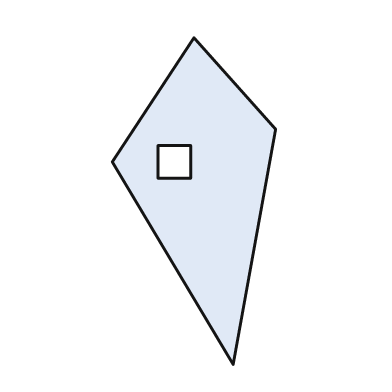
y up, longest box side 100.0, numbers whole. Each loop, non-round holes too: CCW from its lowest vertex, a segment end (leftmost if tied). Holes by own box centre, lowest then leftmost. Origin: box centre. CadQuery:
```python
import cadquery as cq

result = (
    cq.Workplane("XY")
    .moveTo(12.0, -50.0)
    .lineTo(25.0, 22.0)
    .lineTo(0.0, 50.0)
    .lineTo(-25.0, 12.0)
    .close()
    .moveTo(-11.0, 7.0)
    .lineTo(-1.0, 7.0)
    .lineTo(-1.0, 17.0)
    .lineTo(-11.0, 17.0)
    .close()
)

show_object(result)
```